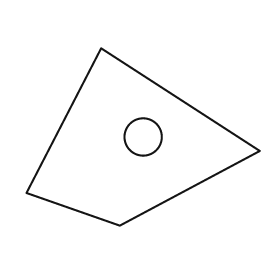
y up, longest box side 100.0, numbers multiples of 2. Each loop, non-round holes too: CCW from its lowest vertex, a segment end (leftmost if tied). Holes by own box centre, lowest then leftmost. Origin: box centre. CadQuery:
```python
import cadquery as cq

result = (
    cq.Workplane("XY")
    .moveTo(-10.0, -38.0)
    .lineTo(50.0, -6.0)
    .lineTo(-18.0, 38.0)
    .lineTo(-50.0, -24.0)
    .close()
    .moveTo(0.0, 0.0)
    .circle(8.0)
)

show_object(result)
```